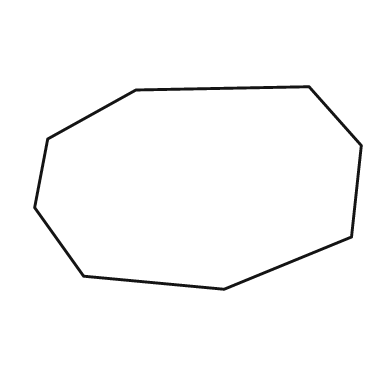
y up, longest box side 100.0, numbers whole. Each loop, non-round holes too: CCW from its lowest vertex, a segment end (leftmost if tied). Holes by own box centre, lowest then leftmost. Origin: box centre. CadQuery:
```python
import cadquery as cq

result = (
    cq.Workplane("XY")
    .moveTo(8.0, -31.0)
    .lineTo(47.0, -15.0)
    .lineTo(50.0, 13.0)
    .lineTo(34.0, 31.0)
    .lineTo(-19.0, 30.0)
    .lineTo(-46.0, 15.0)
    .lineTo(-50.0, -6.0)
    .lineTo(-35.0, -27.0)
    .close()
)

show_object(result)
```